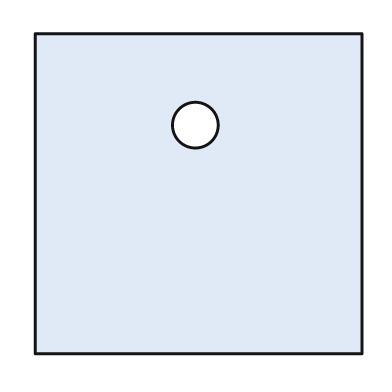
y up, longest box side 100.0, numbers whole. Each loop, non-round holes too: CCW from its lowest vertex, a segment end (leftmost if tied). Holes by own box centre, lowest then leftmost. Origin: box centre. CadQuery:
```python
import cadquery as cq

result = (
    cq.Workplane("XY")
    .moveTo(-50.0, -49.0)
    .lineTo(50.0, -49.0)
    .lineTo(50.0, 49.0)
    .lineTo(-50.0, 49.0)
    .close()
    .moveTo(-1.0, 21.0)
    .circle(7.0)
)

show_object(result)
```